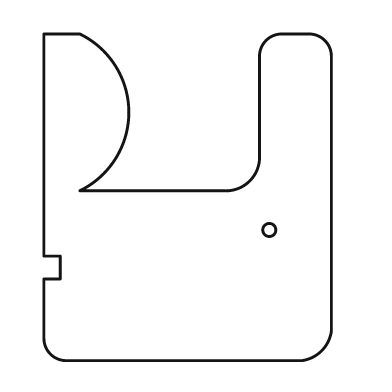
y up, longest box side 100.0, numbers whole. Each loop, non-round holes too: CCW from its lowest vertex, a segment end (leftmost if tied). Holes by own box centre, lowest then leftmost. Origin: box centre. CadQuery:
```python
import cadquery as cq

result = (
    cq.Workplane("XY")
    .moveTo(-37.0, -50.0)
    .lineTo(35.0, -50.0)
    .threePointArc((41.0, -47.0), (44.0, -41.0))
    .lineTo(44.0, 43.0)
    .threePointArc((42.0, 48.0), (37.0, 50.0))
    .lineTo(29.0, 50.0)
    .threePointArc((24.0, 48.0), (22.0, 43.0))
    .lineTo(22.0, 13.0)
    .threePointArc((19.0, 5.0), (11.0, 2.0))
    .lineTo(-33.0, 2.0)
    .threePointArc((-18.0, 26.0), (-33.0, 50.0))
    .lineTo(-44.0, 50.0)
    .lineTo(-44.0, -18.0)
    .lineTo(-39.0, -18.0)
    .lineTo(-39.0, -25.0)
    .lineTo(-44.0, -25.0)
    .lineTo(-44.0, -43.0)
    .threePointArc((-42.0, -48.0), (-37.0, -50.0))
    .close()
    .moveTo(25.0, -10.0)
    .circle(2.0)
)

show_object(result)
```